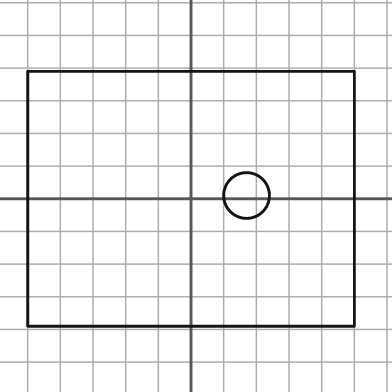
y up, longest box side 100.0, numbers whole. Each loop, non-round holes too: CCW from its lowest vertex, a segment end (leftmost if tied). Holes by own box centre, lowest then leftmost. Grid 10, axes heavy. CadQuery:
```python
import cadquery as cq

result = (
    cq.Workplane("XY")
    .moveTo(-50.0, -39.0)
    .lineTo(50.0, -39.0)
    .lineTo(50.0, 39.0)
    .lineTo(-50.0, 39.0)
    .close()
    .moveTo(17.0, 1.0)
    .circle(7.0)
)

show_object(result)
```